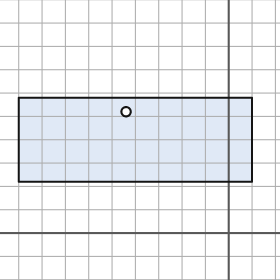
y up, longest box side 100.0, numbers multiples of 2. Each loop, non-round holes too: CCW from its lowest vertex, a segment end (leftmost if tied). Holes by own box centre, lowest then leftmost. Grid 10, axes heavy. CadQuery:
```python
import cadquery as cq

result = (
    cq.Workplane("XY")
    .moveTo(-90.0, 22.0)
    .lineTo(10.0, 22.0)
    .lineTo(10.0, 58.0)
    .lineTo(-90.0, 58.0)
    .close()
    .moveTo(-44.0, 52.0)
    .circle(2.0)
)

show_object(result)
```